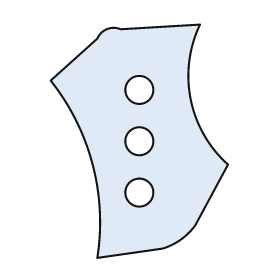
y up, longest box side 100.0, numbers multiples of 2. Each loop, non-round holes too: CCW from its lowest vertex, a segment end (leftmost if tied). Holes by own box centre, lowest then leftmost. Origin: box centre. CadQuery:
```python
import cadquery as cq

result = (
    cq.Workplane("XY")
    .moveTo(-18.0, -50.0)
    .lineTo(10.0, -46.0)
    .threePointArc((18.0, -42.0), (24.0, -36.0))
    .lineTo(38.0, -10.0)
    .threePointArc((22.0, 18.0), (26.0, 50.0))
    .lineTo(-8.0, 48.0)
    .threePointArc((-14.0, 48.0), (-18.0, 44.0))
    .lineTo(-38.0, 26.0)
    .threePointArc((-20.0, -10.0), (-18.0, -50.0))
    .close()
    .moveTo(0.0, -22.0)
    .circle(6.0)
    .moveTo(0.0, 0.0)
    .circle(6.0)
    .moveTo(0.0, 22.0)
    .circle(6.0)
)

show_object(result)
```